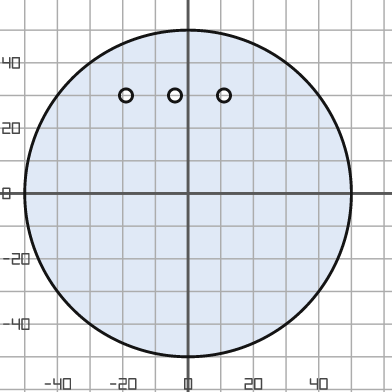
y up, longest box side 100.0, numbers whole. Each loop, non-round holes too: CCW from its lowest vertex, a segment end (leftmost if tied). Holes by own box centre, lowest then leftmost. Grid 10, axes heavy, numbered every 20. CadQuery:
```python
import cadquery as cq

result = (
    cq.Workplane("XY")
    .moveTo(0.0, 0.0)
    .circle(50.0)
    .moveTo(-19.0, 30.0)
    .circle(2.0)
    .moveTo(-4.0, 30.0)
    .circle(2.0)
    .moveTo(11.0, 30.0)
    .circle(2.0)
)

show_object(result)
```